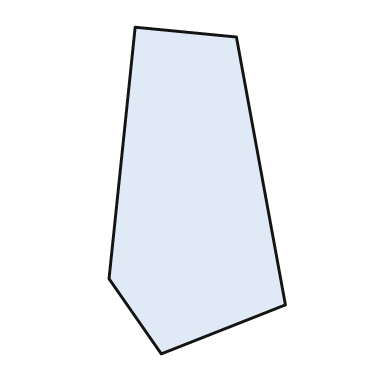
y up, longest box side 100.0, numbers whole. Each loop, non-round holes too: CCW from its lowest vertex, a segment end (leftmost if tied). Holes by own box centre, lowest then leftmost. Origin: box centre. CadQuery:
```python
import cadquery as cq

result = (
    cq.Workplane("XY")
    .moveTo(-11.0, -50.0)
    .lineTo(27.0, -35.0)
    .lineTo(12.0, 47.0)
    .lineTo(-19.0, 50.0)
    .lineTo(-27.0, -27.0)
    .close()
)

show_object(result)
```